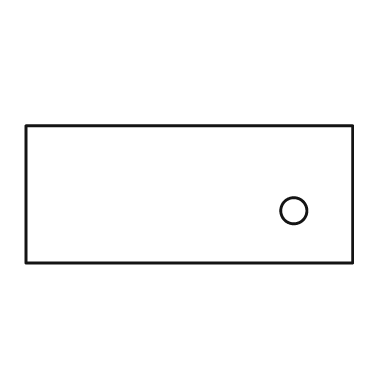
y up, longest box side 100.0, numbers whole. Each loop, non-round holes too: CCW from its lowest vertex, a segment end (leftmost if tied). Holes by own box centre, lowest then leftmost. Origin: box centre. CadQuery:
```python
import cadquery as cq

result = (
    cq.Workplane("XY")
    .moveTo(-50.0, -21.0)
    .lineTo(50.0, -21.0)
    .lineTo(50.0, 21.0)
    .lineTo(-50.0, 21.0)
    .close()
    .moveTo(32.0, -5.0)
    .circle(4.0)
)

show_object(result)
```